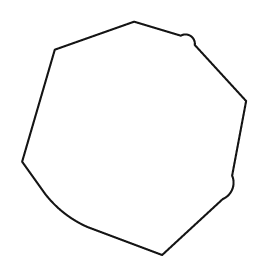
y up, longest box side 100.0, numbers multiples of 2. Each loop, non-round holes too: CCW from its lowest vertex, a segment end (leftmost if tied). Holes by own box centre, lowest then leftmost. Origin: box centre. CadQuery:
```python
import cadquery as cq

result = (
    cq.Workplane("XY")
    .moveTo(12.0, -50.0)
    .lineTo(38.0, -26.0)
    .threePointArc((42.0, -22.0), (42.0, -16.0))
    .lineTo(48.0, 16.0)
    .lineTo(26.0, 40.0)
    .threePointArc((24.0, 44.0), (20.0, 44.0))
    .lineTo(0.0, 50.0)
    .lineTo(-34.0, 38.0)
    .lineTo(-48.0, -10.0)
    .lineTo(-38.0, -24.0)
    .threePointArc((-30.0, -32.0), (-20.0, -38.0))
    .close()
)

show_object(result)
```